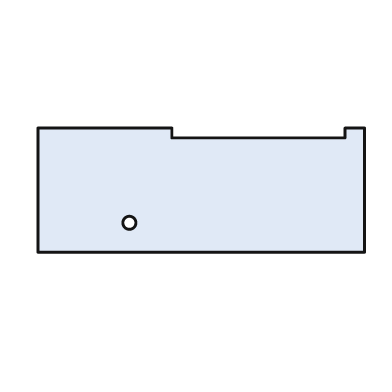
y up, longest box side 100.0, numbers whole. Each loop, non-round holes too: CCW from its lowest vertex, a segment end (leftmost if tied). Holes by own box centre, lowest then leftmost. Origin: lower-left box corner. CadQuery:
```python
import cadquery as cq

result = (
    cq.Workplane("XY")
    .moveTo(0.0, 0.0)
    .lineTo(100.0, 0.0)
    .lineTo(100.0, 38.0)
    .lineTo(94.0, 38.0)
    .lineTo(94.0, 35.0)
    .lineTo(41.0, 35.0)
    .lineTo(41.0, 38.0)
    .lineTo(0.0, 38.0)
    .close()
    .moveTo(28.0, 9.0)
    .circle(2.0)
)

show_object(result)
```